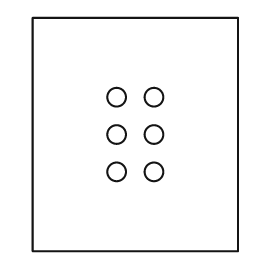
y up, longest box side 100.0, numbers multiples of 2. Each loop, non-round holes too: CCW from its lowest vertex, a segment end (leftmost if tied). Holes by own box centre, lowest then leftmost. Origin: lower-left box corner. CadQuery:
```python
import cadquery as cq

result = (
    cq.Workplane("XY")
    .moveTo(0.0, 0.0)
    .lineTo(88.0, 0.0)
    .lineTo(88.0, 100.0)
    .lineTo(0.0, 100.0)
    .close()
    .moveTo(36.0, 34.0)
    .circle(4.0)
    .moveTo(52.0, 34.0)
    .circle(4.0)
    .moveTo(36.0, 50.0)
    .circle(4.0)
    .moveTo(52.0, 50.0)
    .circle(4.0)
    .moveTo(36.0, 66.0)
    .circle(4.0)
    .moveTo(52.0, 66.0)
    .circle(4.0)
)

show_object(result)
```